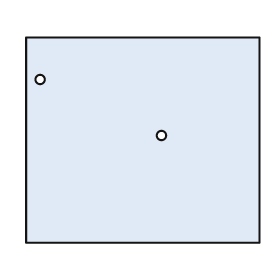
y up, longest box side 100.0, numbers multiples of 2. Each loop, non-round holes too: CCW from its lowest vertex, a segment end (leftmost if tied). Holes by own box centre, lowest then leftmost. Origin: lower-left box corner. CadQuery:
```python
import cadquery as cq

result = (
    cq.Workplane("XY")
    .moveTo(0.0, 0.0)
    .lineTo(100.0, 0.0)
    .lineTo(100.0, 88.0)
    .lineTo(0.0, 88.0)
    .close()
    .moveTo(58.0, 46.0)
    .circle(2.0)
    .moveTo(6.0, 70.0)
    .circle(2.0)
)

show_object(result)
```